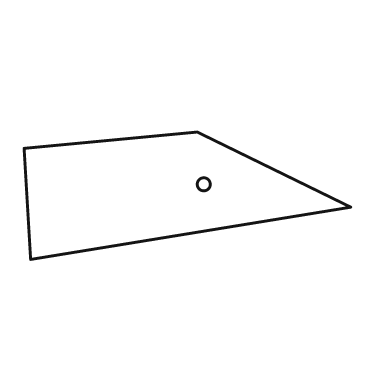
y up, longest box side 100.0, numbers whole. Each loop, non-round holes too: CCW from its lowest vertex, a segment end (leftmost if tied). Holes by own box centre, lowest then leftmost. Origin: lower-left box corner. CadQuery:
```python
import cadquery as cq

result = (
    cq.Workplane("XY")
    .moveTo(2.0, 0.0)
    .lineTo(100.0, 16.0)
    .lineTo(53.0, 39.0)
    .lineTo(0.0, 34.0)
    .close()
    .moveTo(55.0, 23.0)
    .circle(2.0)
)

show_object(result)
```